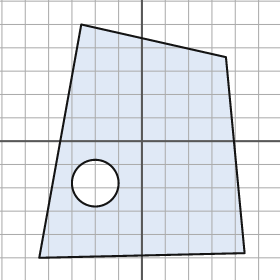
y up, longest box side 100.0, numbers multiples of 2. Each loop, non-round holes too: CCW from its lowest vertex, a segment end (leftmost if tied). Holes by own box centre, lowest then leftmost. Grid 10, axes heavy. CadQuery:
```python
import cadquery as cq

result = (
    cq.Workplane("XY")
    .moveTo(-44.0, -50.0)
    .lineTo(44.0, -48.0)
    .lineTo(36.0, 36.0)
    .lineTo(-26.0, 50.0)
    .close()
    .moveTo(-20.0, -18.0)
    .circle(10.0)
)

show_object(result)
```